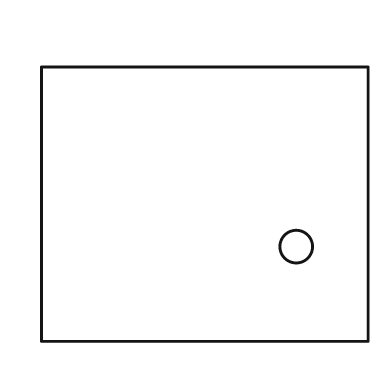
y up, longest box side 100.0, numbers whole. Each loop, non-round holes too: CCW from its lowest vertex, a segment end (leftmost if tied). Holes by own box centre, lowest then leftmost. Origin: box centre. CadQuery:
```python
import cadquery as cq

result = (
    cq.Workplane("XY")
    .moveTo(-50.0, -42.0)
    .lineTo(50.0, -42.0)
    .lineTo(50.0, 42.0)
    .lineTo(-50.0, 42.0)
    .close()
    .moveTo(28.0, -13.0)
    .circle(5.0)
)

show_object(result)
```